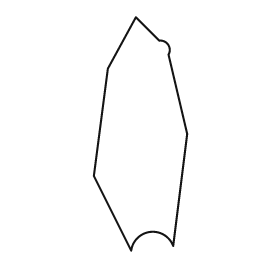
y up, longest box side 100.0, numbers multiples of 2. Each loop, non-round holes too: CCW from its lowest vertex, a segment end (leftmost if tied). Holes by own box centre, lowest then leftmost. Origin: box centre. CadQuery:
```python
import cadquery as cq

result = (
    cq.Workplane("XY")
    .moveTo(-4.0, -50.0)
    .threePointArc((4.0, -42.0), (14.0, -48.0))
    .lineTo(20.0, 0.0)
    .lineTo(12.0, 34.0)
    .threePointArc((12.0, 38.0), (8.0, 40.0))
    .lineTo(-2.0, 50.0)
    .lineTo(-14.0, 28.0)
    .lineTo(-20.0, -18.0)
    .close()
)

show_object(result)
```